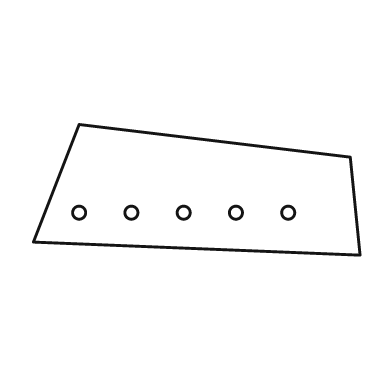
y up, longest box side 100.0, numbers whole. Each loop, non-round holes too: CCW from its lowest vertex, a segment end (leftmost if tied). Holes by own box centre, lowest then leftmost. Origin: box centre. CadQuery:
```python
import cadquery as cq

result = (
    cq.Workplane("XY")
    .moveTo(50.0, -20.0)
    .lineTo(47.0, 10.0)
    .lineTo(-36.0, 20.0)
    .lineTo(-50.0, -16.0)
    .close()
    .moveTo(-36.0, -7.0)
    .circle(2.0)
    .moveTo(-20.0, -7.0)
    .circle(2.0)
    .moveTo(-4.0, -7.0)
    .circle(2.0)
    .moveTo(12.0, -7.0)
    .circle(2.0)
    .moveTo(28.0, -7.0)
    .circle(2.0)
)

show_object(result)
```